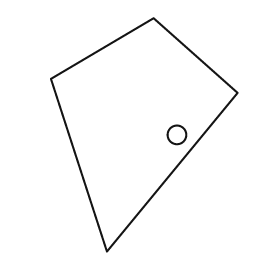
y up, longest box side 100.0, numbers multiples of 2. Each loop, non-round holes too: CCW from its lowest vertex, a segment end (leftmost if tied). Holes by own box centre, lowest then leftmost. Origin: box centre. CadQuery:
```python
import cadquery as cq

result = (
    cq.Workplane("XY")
    .moveTo(-16.0, -50.0)
    .lineTo(40.0, 18.0)
    .lineTo(4.0, 50.0)
    .lineTo(-40.0, 24.0)
    .close()
    .moveTo(14.0, 0.0)
    .circle(4.0)
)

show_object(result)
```